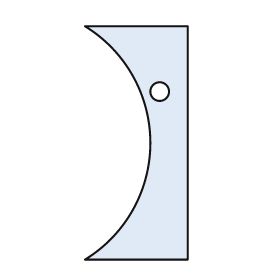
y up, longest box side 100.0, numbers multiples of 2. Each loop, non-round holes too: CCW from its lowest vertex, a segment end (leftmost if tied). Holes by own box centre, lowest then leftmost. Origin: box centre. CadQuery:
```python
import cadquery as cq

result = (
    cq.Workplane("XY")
    .moveTo(-22.0, -50.0)
    .lineTo(22.0, -50.0)
    .lineTo(22.0, 50.0)
    .lineTo(-22.0, 50.0)
    .threePointArc((6.0, 0.0), (-22.0, -50.0))
    .close()
    .moveTo(10.0, 22.0)
    .circle(4.0)
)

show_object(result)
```